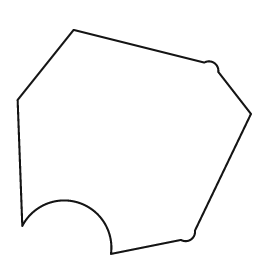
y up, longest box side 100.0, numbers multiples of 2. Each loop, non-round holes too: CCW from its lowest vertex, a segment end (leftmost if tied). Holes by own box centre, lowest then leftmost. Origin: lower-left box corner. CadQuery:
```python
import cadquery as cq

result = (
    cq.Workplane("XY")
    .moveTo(40.0, 0.0)
    .lineTo(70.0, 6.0)
    .threePointArc((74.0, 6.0), (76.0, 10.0))
    .lineTo(100.0, 60.0)
    .lineTo(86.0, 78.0)
    .threePointArc((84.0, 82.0), (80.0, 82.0))
    .lineTo(24.0, 96.0)
    .lineTo(0.0, 66.0)
    .lineTo(2.0, 12.0)
    .threePointArc((26.0, 22.0), (40.0, 0.0))
    .close()
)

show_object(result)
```